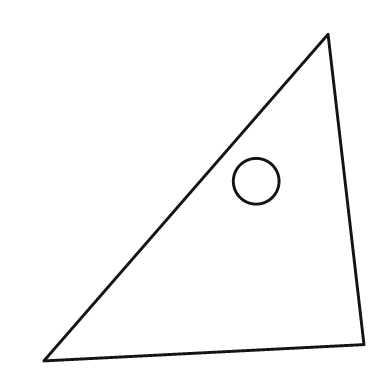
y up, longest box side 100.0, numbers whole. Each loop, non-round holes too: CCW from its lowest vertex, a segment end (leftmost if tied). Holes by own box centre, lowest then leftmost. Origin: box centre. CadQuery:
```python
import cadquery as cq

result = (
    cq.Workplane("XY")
    .moveTo(-49.0, -50.0)
    .lineTo(49.0, -45.0)
    .lineTo(38.0, 50.0)
    .close()
    .moveTo(16.0, 5.0)
    .circle(7.0)
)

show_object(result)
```